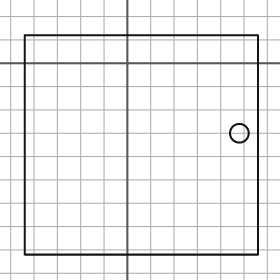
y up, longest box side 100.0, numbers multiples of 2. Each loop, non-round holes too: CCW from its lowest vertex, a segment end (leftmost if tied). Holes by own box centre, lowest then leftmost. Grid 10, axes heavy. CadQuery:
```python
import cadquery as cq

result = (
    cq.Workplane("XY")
    .moveTo(-44.0, -82.0)
    .lineTo(56.0, -82.0)
    .lineTo(56.0, 12.0)
    .lineTo(-44.0, 12.0)
    .close()
    .moveTo(48.0, -30.0)
    .circle(4.0)
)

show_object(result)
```